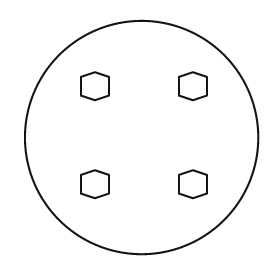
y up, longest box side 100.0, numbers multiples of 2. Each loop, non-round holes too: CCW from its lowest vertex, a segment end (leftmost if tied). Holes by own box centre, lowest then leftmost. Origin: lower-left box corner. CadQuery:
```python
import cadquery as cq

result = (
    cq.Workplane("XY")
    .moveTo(50.0, 50.0)
    .circle(50.0)
    .moveTo(30.0, 24.0)
    .lineTo(36.0, 26.0)
    .lineTo(36.0, 34.0)
    .lineTo(30.0, 36.0)
    .lineTo(24.0, 34.0)
    .lineTo(24.0, 26.0)
    .close()
    .moveTo(72.0, 24.0)
    .lineTo(78.0, 26.0)
    .lineTo(78.0, 34.0)
    .lineTo(72.0, 36.0)
    .lineTo(66.0, 34.0)
    .lineTo(66.0, 26.0)
    .close()
    .moveTo(30.0, 66.0)
    .lineTo(36.0, 68.0)
    .lineTo(36.0, 76.0)
    .lineTo(30.0, 78.0)
    .lineTo(24.0, 76.0)
    .lineTo(24.0, 68.0)
    .close()
    .moveTo(72.0, 66.0)
    .lineTo(78.0, 68.0)
    .lineTo(78.0, 76.0)
    .lineTo(72.0, 78.0)
    .lineTo(66.0, 76.0)
    .lineTo(66.0, 68.0)
    .close()
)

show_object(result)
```